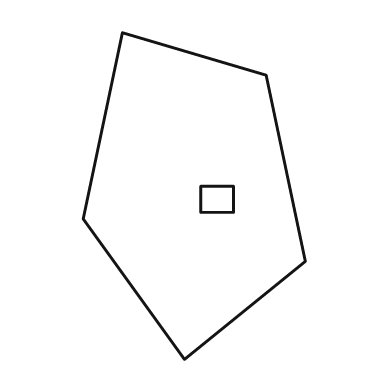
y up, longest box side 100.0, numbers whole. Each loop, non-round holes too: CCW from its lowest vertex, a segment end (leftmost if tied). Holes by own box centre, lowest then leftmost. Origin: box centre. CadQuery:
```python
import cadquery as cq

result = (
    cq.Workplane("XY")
    .moveTo(-3.0, -50.0)
    .lineTo(34.0, -20.0)
    .lineTo(22.0, 37.0)
    .lineTo(-22.0, 50.0)
    .lineTo(-34.0, -7.0)
    .close()
    .moveTo(2.0, -5.0)
    .lineTo(12.0, -5.0)
    .lineTo(12.0, 3.0)
    .lineTo(2.0, 3.0)
    .close()
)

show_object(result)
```